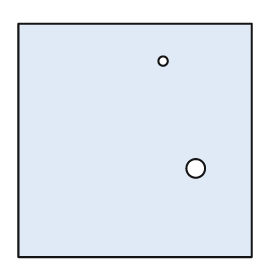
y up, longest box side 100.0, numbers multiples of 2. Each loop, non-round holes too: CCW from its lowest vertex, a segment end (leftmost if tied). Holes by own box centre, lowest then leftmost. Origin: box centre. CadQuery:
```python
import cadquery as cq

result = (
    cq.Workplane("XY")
    .moveTo(-50.0, -50.0)
    .lineTo(50.0, -50.0)
    .lineTo(50.0, 50.0)
    .lineTo(-50.0, 50.0)
    .close()
    .moveTo(26.0, -12.0)
    .circle(4.0)
    .moveTo(12.0, 34.0)
    .circle(2.0)
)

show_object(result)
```